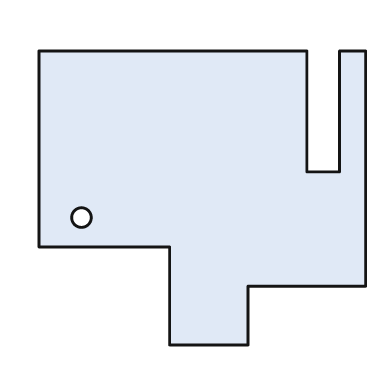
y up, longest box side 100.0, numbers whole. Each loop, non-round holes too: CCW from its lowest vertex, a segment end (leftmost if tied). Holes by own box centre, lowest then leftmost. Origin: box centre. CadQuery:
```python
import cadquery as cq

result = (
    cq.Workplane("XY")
    .moveTo(-10.0, -45.0)
    .lineTo(14.0, -45.0)
    .lineTo(14.0, -27.0)
    .lineTo(50.0, -27.0)
    .lineTo(50.0, 45.0)
    .lineTo(42.0, 45.0)
    .lineTo(42.0, 8.0)
    .lineTo(32.0, 8.0)
    .lineTo(32.0, 45.0)
    .lineTo(-50.0, 45.0)
    .lineTo(-50.0, -15.0)
    .lineTo(-10.0, -15.0)
    .close()
    .moveTo(-37.0, -6.0)
    .circle(3.0)
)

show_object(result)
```